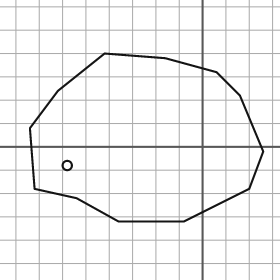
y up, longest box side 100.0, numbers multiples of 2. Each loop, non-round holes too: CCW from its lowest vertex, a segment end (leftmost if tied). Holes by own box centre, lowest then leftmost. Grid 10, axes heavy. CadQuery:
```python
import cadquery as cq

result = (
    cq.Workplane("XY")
    .moveTo(-36.0, -32.0)
    .lineTo(-8.0, -32.0)
    .lineTo(20.0, -18.0)
    .lineTo(26.0, -2.0)
    .lineTo(16.0, 22.0)
    .lineTo(6.0, 32.0)
    .lineTo(-16.0, 38.0)
    .lineTo(-42.0, 40.0)
    .lineTo(-62.0, 24.0)
    .lineTo(-74.0, 8.0)
    .lineTo(-72.0, -18.0)
    .lineTo(-54.0, -22.0)
    .close()
    .moveTo(-58.0, -8.0)
    .circle(2.0)
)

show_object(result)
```